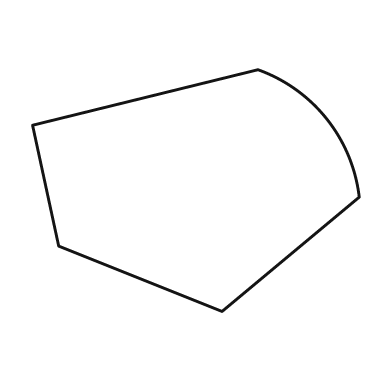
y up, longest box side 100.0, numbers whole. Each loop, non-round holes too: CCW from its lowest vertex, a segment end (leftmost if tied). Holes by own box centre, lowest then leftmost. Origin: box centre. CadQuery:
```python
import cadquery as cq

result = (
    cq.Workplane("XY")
    .moveTo(8.0, -37.0)
    .lineTo(50.0, -2.0)
    .threePointArc((40.0, 22.0), (19.0, 37.0))
    .lineTo(-50.0, 20.0)
    .lineTo(-42.0, -17.0)
    .close()
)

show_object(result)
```